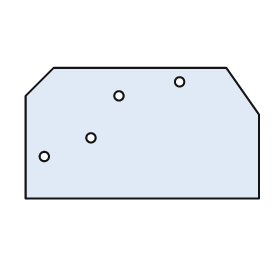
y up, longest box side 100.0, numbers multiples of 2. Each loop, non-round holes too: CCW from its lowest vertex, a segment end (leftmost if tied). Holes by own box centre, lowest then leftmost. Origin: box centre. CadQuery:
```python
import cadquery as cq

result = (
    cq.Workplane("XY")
    .moveTo(-50.0, -28.0)
    .lineTo(50.0, -28.0)
    .lineTo(50.0, 8.0)
    .lineTo(36.0, 28.0)
    .lineTo(-38.0, 28.0)
    .lineTo(-50.0, 16.0)
    .close()
    .moveTo(-42.0, -10.0)
    .circle(2.0)
    .moveTo(-22.0, -2.0)
    .circle(2.0)
    .moveTo(-10.0, 16.0)
    .circle(2.0)
    .moveTo(16.0, 22.0)
    .circle(2.0)
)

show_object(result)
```